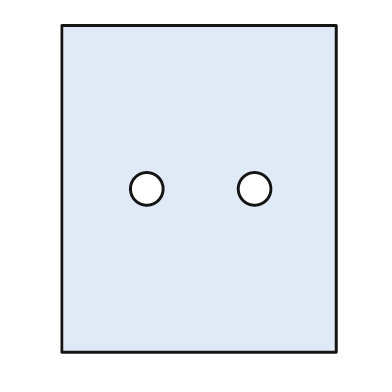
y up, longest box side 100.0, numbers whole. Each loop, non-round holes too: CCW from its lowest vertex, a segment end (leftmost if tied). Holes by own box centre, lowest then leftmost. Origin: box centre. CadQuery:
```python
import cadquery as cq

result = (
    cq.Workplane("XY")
    .moveTo(-42.0, -50.0)
    .lineTo(42.0, -50.0)
    .lineTo(42.0, 50.0)
    .lineTo(-42.0, 50.0)
    .close()
    .moveTo(-16.0, 0.0)
    .circle(5.0)
    .moveTo(17.0, 0.0)
    .circle(5.0)
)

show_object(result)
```